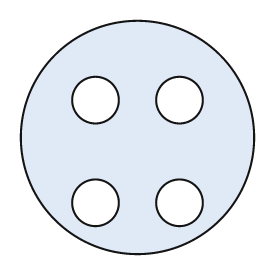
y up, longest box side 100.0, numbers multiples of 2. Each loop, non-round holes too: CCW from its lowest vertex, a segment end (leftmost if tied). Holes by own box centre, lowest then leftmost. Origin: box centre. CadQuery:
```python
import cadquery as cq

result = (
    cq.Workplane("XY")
    .moveTo(0.0, 0.0)
    .circle(50.0)
    .moveTo(-18.0, -28.0)
    .circle(10.0)
    .moveTo(18.0, -28.0)
    .circle(10.0)
    .moveTo(-18.0, 16.0)
    .circle(10.0)
    .moveTo(18.0, 16.0)
    .circle(10.0)
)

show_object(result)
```